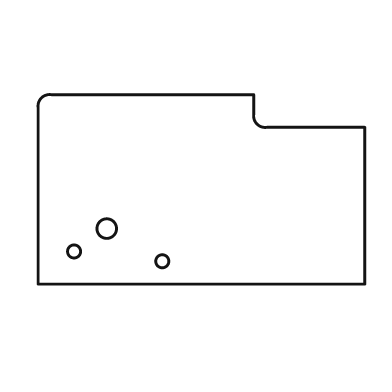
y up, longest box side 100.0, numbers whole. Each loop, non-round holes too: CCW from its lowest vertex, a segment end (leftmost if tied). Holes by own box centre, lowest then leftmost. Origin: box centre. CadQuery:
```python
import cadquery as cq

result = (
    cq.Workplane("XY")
    .moveTo(-50.0, -29.0)
    .lineTo(50.0, -29.0)
    .lineTo(50.0, 19.0)
    .lineTo(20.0, 19.0)
    .threePointArc((17.0, 20.0), (16.0, 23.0))
    .lineTo(16.0, 29.0)
    .lineTo(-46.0, 29.0)
    .threePointArc((-49.0, 28.0), (-50.0, 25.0))
    .close()
    .moveTo(-12.0, -22.0)
    .circle(2.0)
    .moveTo(-39.0, -19.0)
    .circle(2.0)
    .moveTo(-29.0, -12.0)
    .circle(3.0)
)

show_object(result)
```